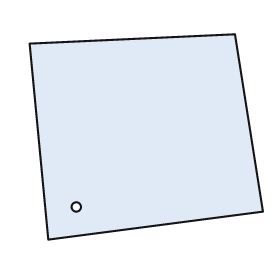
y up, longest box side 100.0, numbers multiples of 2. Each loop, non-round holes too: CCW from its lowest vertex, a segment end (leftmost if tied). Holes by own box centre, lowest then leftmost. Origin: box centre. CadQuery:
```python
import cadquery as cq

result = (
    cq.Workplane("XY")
    .moveTo(-42.0, -44.0)
    .lineTo(50.0, -32.0)
    .lineTo(38.0, 44.0)
    .lineTo(-50.0, 40.0)
    .close()
    .moveTo(-30.0, -30.0)
    .circle(2.0)
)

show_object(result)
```